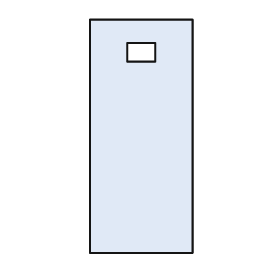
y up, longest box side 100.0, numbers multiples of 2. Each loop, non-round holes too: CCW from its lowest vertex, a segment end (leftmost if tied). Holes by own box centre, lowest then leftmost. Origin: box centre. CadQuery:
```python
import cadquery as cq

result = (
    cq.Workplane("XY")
    .moveTo(-22.0, -50.0)
    .lineTo(22.0, -50.0)
    .lineTo(22.0, 50.0)
    .lineTo(-22.0, 50.0)
    .close()
    .moveTo(-6.0, 32.0)
    .lineTo(6.0, 32.0)
    .lineTo(6.0, 40.0)
    .lineTo(-6.0, 40.0)
    .close()
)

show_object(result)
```